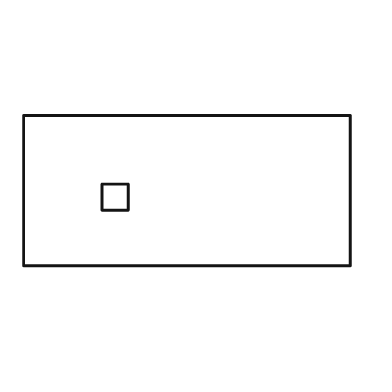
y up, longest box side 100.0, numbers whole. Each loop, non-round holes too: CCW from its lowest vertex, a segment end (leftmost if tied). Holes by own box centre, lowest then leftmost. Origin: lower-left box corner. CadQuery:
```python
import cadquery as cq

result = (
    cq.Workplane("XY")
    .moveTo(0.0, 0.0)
    .lineTo(100.0, 0.0)
    .lineTo(100.0, 46.0)
    .lineTo(0.0, 46.0)
    .close()
    .moveTo(24.0, 17.0)
    .lineTo(32.0, 17.0)
    .lineTo(32.0, 25.0)
    .lineTo(24.0, 25.0)
    .close()
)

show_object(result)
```